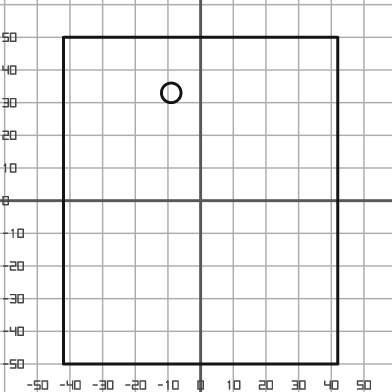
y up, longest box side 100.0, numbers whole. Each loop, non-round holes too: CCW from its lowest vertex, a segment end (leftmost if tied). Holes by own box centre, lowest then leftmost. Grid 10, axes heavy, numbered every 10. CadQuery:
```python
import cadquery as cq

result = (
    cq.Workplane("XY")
    .moveTo(-42.0, -50.0)
    .lineTo(42.0, -50.0)
    .lineTo(42.0, 50.0)
    .lineTo(-42.0, 50.0)
    .close()
    .moveTo(-9.0, 33.0)
    .circle(3.0)
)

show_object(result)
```